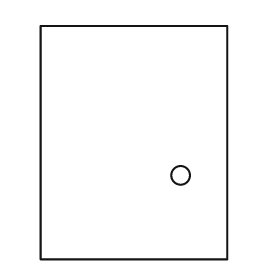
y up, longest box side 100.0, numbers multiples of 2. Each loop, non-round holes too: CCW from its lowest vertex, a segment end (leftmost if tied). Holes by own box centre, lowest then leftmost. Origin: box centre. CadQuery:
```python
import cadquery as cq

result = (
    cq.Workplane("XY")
    .moveTo(-40.0, -50.0)
    .lineTo(40.0, -50.0)
    .lineTo(40.0, 50.0)
    .lineTo(-40.0, 50.0)
    .close()
    .moveTo(20.0, -14.0)
    .circle(4.0)
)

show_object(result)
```